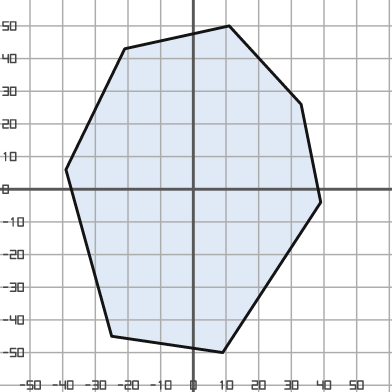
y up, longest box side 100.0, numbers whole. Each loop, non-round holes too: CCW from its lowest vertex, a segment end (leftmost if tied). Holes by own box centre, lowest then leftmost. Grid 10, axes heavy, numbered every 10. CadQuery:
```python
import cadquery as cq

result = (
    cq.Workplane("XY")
    .moveTo(9.0, -50.0)
    .lineTo(39.0, -4.0)
    .lineTo(33.0, 26.0)
    .lineTo(11.0, 50.0)
    .lineTo(-21.0, 43.0)
    .lineTo(-39.0, 6.0)
    .lineTo(-25.0, -45.0)
    .close()
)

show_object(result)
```